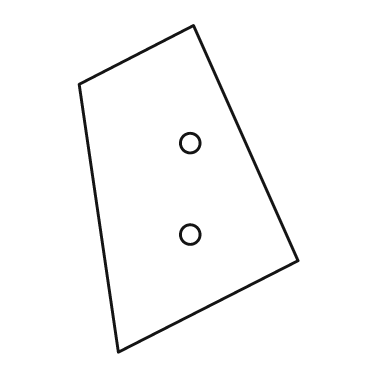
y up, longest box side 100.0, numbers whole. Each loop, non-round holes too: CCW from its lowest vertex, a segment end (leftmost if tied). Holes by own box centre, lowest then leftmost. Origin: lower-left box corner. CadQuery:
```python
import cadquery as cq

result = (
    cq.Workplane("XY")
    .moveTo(12.0, 0.0)
    .lineTo(67.0, 28.0)
    .lineTo(35.0, 100.0)
    .lineTo(0.0, 82.0)
    .close()
    .moveTo(34.0, 36.0)
    .circle(3.0)
    .moveTo(34.0, 64.0)
    .circle(3.0)
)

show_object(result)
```